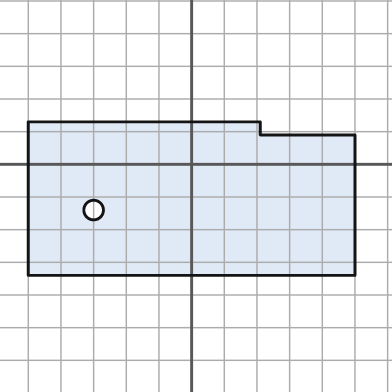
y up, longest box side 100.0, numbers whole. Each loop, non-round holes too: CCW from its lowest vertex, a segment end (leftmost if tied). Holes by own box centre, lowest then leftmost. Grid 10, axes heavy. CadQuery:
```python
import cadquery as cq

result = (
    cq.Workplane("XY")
    .moveTo(-50.0, -34.0)
    .lineTo(50.0, -34.0)
    .lineTo(50.0, 9.0)
    .lineTo(21.0, 9.0)
    .lineTo(21.0, 13.0)
    .lineTo(-50.0, 13.0)
    .close()
    .moveTo(-30.0, -14.0)
    .circle(3.0)
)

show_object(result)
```